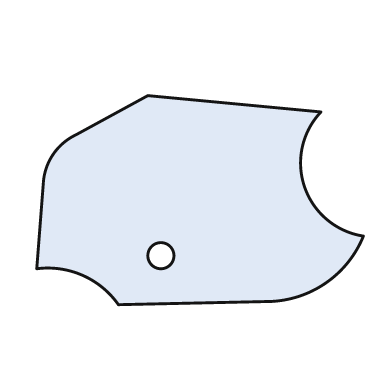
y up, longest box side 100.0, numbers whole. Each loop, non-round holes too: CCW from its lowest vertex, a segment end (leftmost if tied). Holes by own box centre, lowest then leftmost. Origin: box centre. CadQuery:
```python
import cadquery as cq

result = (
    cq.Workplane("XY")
    .moveTo(-25.0, -32.0)
    .lineTo(22.0, -31.0)
    .threePointArc((39.0, -25.0), (50.0, -11.0))
    .threePointArc((32.0, 4.0), (37.0, 27.0))
    .lineTo(-16.0, 32.0)
    .lineTo(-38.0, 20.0)
    .threePointArc((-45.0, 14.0), (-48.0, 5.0))
    .lineTo(-50.0, -21.0)
    .threePointArc((-36.0, -23.0), (-25.0, -32.0))
    .close()
    .moveTo(-12.0, -17.0)
    .circle(4.0)
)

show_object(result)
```